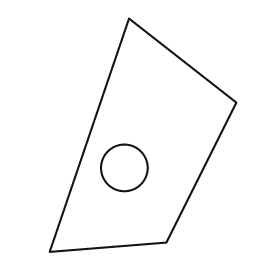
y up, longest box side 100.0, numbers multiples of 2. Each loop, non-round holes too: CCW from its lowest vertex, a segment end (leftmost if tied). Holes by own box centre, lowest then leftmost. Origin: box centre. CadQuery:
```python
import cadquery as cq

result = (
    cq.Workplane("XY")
    .moveTo(-40.0, -50.0)
    .lineTo(10.0, -46.0)
    .lineTo(40.0, 14.0)
    .lineTo(-6.0, 50.0)
    .close()
    .moveTo(-8.0, -14.0)
    .circle(10.0)
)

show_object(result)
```